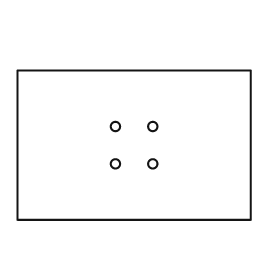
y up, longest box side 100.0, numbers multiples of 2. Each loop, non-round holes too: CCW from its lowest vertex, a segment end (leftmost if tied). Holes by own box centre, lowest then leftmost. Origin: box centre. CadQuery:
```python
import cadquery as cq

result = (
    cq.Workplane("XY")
    .moveTo(-50.0, -32.0)
    .lineTo(50.0, -32.0)
    .lineTo(50.0, 32.0)
    .lineTo(-50.0, 32.0)
    .close()
    .moveTo(-8.0, -8.0)
    .circle(2.0)
    .moveTo(8.0, -8.0)
    .circle(2.0)
    .moveTo(-8.0, 8.0)
    .circle(2.0)
    .moveTo(8.0, 8.0)
    .circle(2.0)
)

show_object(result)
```